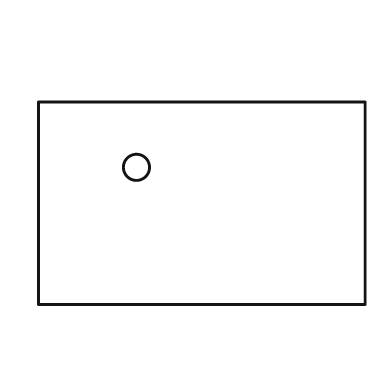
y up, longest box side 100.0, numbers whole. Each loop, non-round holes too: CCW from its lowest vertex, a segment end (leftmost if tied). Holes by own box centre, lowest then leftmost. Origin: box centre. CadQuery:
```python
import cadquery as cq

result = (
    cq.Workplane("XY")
    .moveTo(-50.0, -31.0)
    .lineTo(50.0, -31.0)
    .lineTo(50.0, 31.0)
    .lineTo(-50.0, 31.0)
    .close()
    .moveTo(-20.0, 11.0)
    .circle(4.0)
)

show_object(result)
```